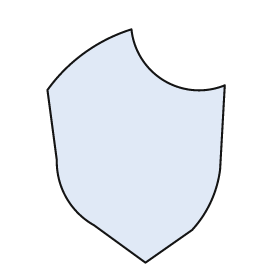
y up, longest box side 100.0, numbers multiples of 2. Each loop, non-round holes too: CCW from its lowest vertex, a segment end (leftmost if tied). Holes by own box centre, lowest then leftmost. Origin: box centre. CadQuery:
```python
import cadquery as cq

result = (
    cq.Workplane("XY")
    .moveTo(4.0, -50.0)
    .lineTo(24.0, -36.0)
    .threePointArc((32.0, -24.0), (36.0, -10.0))
    .lineTo(38.0, 26.0)
    .threePointArc((12.0, 28.0), (-2.0, 50.0))
    .threePointArc((-22.0, 40.0), (-38.0, 24.0))
    .lineTo(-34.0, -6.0)
    .threePointArc((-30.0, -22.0), (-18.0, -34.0))
    .close()
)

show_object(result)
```